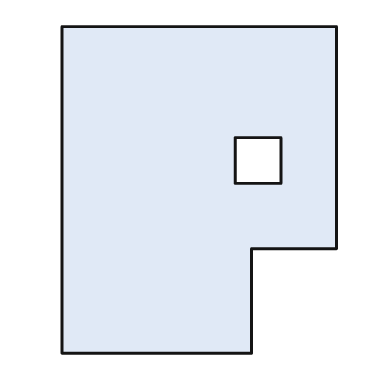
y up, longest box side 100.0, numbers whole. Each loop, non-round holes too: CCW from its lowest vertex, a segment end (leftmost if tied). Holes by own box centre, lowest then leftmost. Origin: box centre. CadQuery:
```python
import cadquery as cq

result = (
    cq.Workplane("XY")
    .moveTo(-42.0, -50.0)
    .lineTo(16.0, -50.0)
    .lineTo(16.0, -18.0)
    .lineTo(42.0, -18.0)
    .lineTo(42.0, 50.0)
    .lineTo(-42.0, 50.0)
    .close()
    .moveTo(11.0, 2.0)
    .lineTo(25.0, 2.0)
    .lineTo(25.0, 16.0)
    .lineTo(11.0, 16.0)
    .close()
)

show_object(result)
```